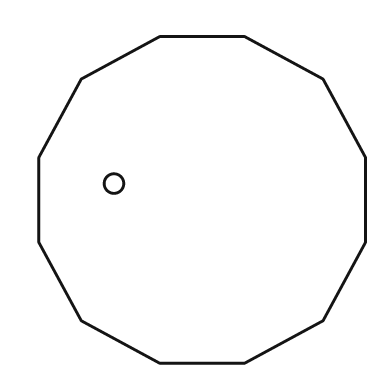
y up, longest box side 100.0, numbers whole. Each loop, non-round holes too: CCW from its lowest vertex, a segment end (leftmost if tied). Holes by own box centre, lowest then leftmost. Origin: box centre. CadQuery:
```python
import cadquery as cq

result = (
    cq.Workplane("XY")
    .moveTo(-13.0, -50.0)
    .lineTo(13.0, -50.0)
    .lineTo(37.0, -37.0)
    .lineTo(50.0, -13.0)
    .lineTo(50.0, 13.0)
    .lineTo(37.0, 37.0)
    .lineTo(13.0, 50.0)
    .lineTo(-13.0, 50.0)
    .lineTo(-37.0, 37.0)
    .lineTo(-50.0, 13.0)
    .lineTo(-50.0, -13.0)
    .lineTo(-37.0, -37.0)
    .close()
    .moveTo(-27.0, 5.0)
    .circle(3.0)
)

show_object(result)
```